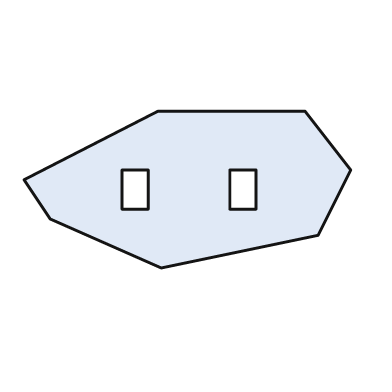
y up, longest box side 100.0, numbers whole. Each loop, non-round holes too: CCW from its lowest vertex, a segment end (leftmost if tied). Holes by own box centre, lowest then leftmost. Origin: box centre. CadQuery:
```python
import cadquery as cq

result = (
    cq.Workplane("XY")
    .moveTo(-8.0, -24.0)
    .lineTo(40.0, -14.0)
    .lineTo(50.0, 6.0)
    .lineTo(36.0, 24.0)
    .lineTo(-9.0, 24.0)
    .lineTo(-50.0, 3.0)
    .lineTo(-42.0, -9.0)
    .close()
    .moveTo(-20.0, -6.0)
    .lineTo(-12.0, -6.0)
    .lineTo(-12.0, 6.0)
    .lineTo(-20.0, 6.0)
    .close()
    .moveTo(13.0, -6.0)
    .lineTo(21.0, -6.0)
    .lineTo(21.0, 6.0)
    .lineTo(13.0, 6.0)
    .close()
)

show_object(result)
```